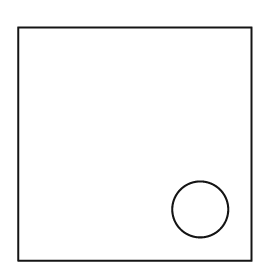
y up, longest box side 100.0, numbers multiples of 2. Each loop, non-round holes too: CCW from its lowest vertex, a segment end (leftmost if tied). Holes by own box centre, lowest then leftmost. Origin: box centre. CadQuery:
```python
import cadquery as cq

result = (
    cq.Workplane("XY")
    .moveTo(-50.0, -50.0)
    .lineTo(50.0, -50.0)
    .lineTo(50.0, 50.0)
    .lineTo(-50.0, 50.0)
    .close()
    .moveTo(28.0, -28.0)
    .circle(12.0)
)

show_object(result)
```